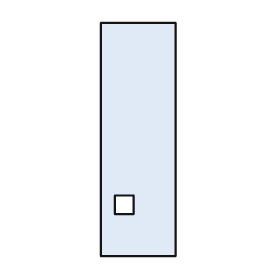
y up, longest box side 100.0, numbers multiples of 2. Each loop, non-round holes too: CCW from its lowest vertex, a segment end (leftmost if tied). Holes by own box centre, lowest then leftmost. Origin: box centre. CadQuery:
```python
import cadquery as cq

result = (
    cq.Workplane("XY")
    .moveTo(-16.0, -50.0)
    .lineTo(16.0, -50.0)
    .lineTo(16.0, 50.0)
    .lineTo(-16.0, 50.0)
    .close()
    .moveTo(-10.0, -32.0)
    .lineTo(-2.0, -32.0)
    .lineTo(-2.0, -24.0)
    .lineTo(-10.0, -24.0)
    .close()
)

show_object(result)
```